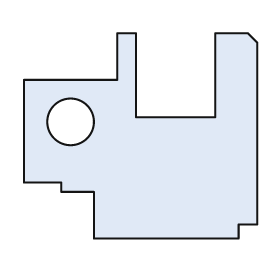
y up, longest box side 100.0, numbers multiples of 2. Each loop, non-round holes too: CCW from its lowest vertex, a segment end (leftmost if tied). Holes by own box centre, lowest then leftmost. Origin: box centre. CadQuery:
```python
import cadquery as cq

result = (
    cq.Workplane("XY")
    .moveTo(-20.0, -44.0)
    .lineTo(42.0, -44.0)
    .lineTo(42.0, -38.0)
    .lineTo(50.0, -38.0)
    .lineTo(50.0, 40.0)
    .lineTo(46.0, 44.0)
    .lineTo(32.0, 44.0)
    .lineTo(32.0, 8.0)
    .lineTo(-2.0, 8.0)
    .lineTo(-2.0, 44.0)
    .lineTo(-10.0, 44.0)
    .lineTo(-10.0, 24.0)
    .lineTo(-50.0, 24.0)
    .lineTo(-50.0, -20.0)
    .lineTo(-34.0, -20.0)
    .lineTo(-34.0, -24.0)
    .lineTo(-20.0, -24.0)
    .close()
    .moveTo(-30.0, 6.0)
    .circle(10.0)
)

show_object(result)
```